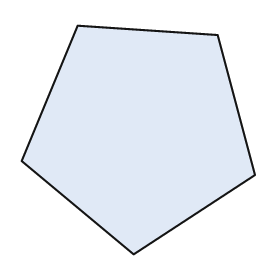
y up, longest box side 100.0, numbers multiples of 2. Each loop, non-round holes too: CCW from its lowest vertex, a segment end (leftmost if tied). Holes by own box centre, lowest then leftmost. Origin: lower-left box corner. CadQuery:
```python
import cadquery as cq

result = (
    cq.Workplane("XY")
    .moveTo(48.0, 0.0)
    .lineTo(100.0, 34.0)
    .lineTo(84.0, 94.0)
    .lineTo(24.0, 98.0)
    .lineTo(0.0, 40.0)
    .close()
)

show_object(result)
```